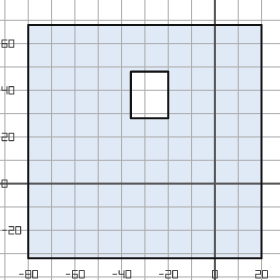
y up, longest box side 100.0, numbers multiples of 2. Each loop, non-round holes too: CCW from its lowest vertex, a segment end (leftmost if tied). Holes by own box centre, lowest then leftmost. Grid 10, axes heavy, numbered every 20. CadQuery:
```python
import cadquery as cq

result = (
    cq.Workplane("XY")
    .moveTo(-80.0, -32.0)
    .lineTo(20.0, -32.0)
    .lineTo(20.0, 68.0)
    .lineTo(-80.0, 68.0)
    .close()
    .moveTo(-36.0, 28.0)
    .lineTo(-20.0, 28.0)
    .lineTo(-20.0, 48.0)
    .lineTo(-36.0, 48.0)
    .close()
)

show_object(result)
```